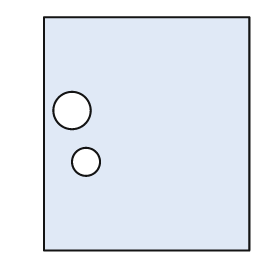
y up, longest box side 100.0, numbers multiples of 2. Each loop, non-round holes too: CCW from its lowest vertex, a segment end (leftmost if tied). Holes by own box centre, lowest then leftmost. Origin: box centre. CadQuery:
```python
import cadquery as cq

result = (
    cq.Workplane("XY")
    .moveTo(-44.0, -50.0)
    .lineTo(44.0, -50.0)
    .lineTo(44.0, 50.0)
    .lineTo(-44.0, 50.0)
    .close()
    .moveTo(-26.0, -12.0)
    .circle(6.0)
    .moveTo(-32.0, 10.0)
    .circle(8.0)
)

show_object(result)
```